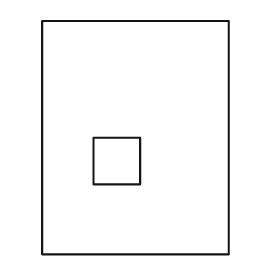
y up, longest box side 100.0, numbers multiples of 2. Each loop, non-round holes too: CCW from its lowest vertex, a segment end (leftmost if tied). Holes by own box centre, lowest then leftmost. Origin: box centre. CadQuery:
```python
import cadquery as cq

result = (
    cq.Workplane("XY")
    .moveTo(-40.0, -50.0)
    .lineTo(40.0, -50.0)
    .lineTo(40.0, 50.0)
    .lineTo(-40.0, 50.0)
    .close()
    .moveTo(-18.0, -20.0)
    .lineTo(2.0, -20.0)
    .lineTo(2.0, 0.0)
    .lineTo(-18.0, 0.0)
    .close()
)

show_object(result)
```